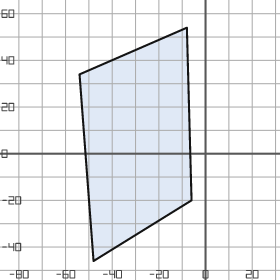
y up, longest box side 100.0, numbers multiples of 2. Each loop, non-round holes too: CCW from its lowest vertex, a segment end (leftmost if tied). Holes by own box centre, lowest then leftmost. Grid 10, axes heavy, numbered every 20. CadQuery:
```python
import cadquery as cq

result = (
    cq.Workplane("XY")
    .moveTo(-48.0, -46.0)
    .lineTo(-6.0, -20.0)
    .lineTo(-8.0, 54.0)
    .lineTo(-54.0, 34.0)
    .close()
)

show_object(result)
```